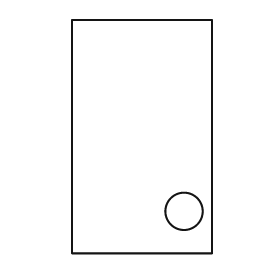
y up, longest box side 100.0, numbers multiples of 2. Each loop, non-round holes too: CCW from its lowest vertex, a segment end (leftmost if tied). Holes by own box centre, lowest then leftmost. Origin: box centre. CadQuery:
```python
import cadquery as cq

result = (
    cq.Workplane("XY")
    .moveTo(-30.0, -50.0)
    .lineTo(30.0, -50.0)
    .lineTo(30.0, 50.0)
    .lineTo(-30.0, 50.0)
    .close()
    .moveTo(18.0, -32.0)
    .circle(8.0)
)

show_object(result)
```